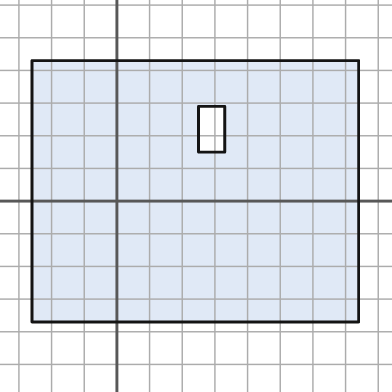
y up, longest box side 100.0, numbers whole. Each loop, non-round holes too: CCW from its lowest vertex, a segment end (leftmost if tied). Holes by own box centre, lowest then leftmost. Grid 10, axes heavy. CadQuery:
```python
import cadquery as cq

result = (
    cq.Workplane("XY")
    .moveTo(-26.0, -37.0)
    .lineTo(74.0, -37.0)
    .lineTo(74.0, 43.0)
    .lineTo(-26.0, 43.0)
    .close()
    .moveTo(25.0, 15.0)
    .lineTo(33.0, 15.0)
    .lineTo(33.0, 29.0)
    .lineTo(25.0, 29.0)
    .close()
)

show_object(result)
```